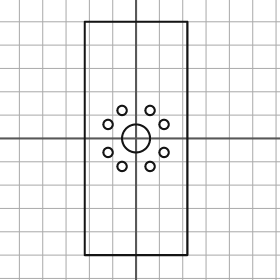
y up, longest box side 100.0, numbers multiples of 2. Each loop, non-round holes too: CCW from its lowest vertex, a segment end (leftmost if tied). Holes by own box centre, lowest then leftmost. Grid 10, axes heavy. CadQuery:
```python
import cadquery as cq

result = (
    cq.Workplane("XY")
    .moveTo(-22.0, -50.0)
    .lineTo(22.0, -50.0)
    .lineTo(22.0, 50.0)
    .lineTo(-22.0, 50.0)
    .close()
    .moveTo(-6.0, -12.0)
    .circle(2.0)
    .moveTo(6.0, -12.0)
    .circle(2.0)
    .moveTo(-12.0, -6.0)
    .circle(2.0)
    .moveTo(12.0, -6.0)
    .circle(2.0)
    .moveTo(0.0, 0.0)
    .circle(6.0)
    .moveTo(-12.0, 6.0)
    .circle(2.0)
    .moveTo(12.0, 6.0)
    .circle(2.0)
    .moveTo(-6.0, 12.0)
    .circle(2.0)
    .moveTo(6.0, 12.0)
    .circle(2.0)
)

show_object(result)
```